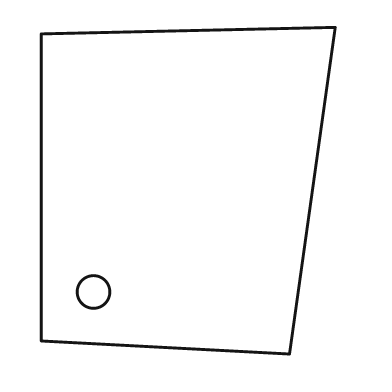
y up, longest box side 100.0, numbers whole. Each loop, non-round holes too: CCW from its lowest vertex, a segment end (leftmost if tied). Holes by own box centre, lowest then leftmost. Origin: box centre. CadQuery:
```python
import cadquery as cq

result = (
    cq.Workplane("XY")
    .moveTo(31.0, -50.0)
    .lineTo(45.0, 50.0)
    .lineTo(-45.0, 48.0)
    .lineTo(-45.0, -46.0)
    .close()
    .moveTo(-29.0, -31.0)
    .circle(5.0)
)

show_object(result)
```